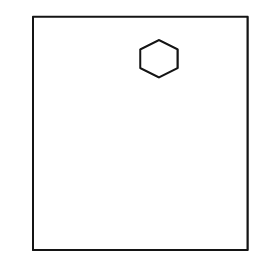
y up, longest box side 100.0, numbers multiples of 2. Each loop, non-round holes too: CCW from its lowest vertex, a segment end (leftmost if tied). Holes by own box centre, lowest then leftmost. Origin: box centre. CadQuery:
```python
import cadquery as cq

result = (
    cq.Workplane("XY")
    .moveTo(-46.0, -50.0)
    .lineTo(46.0, -50.0)
    .lineTo(46.0, 50.0)
    .lineTo(-46.0, 50.0)
    .close()
    .moveTo(8.0, 24.0)
    .lineTo(16.0, 28.0)
    .lineTo(16.0, 36.0)
    .lineTo(8.0, 40.0)
    .lineTo(0.0, 36.0)
    .lineTo(0.0, 28.0)
    .close()
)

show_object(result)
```